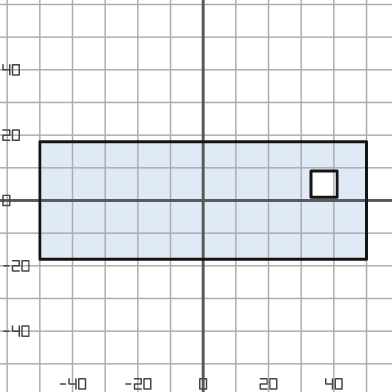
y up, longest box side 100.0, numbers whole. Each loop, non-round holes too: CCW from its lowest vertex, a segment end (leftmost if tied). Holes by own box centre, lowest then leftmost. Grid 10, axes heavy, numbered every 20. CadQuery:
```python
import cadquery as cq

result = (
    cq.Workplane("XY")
    .moveTo(-50.0, -18.0)
    .lineTo(50.0, -18.0)
    .lineTo(50.0, 18.0)
    .lineTo(-50.0, 18.0)
    .close()
    .moveTo(33.0, 1.0)
    .lineTo(41.0, 1.0)
    .lineTo(41.0, 9.0)
    .lineTo(33.0, 9.0)
    .close()
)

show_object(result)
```